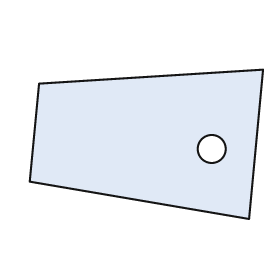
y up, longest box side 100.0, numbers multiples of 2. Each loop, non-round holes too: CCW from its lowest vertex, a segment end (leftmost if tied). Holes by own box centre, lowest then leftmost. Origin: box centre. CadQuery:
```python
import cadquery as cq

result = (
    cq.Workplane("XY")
    .moveTo(44.0, -32.0)
    .lineTo(50.0, 32.0)
    .lineTo(-46.0, 26.0)
    .lineTo(-50.0, -16.0)
    .close()
    .moveTo(28.0, -2.0)
    .circle(6.0)
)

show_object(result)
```